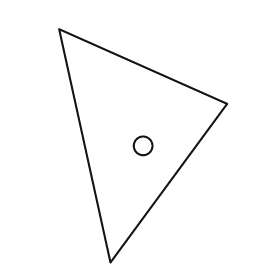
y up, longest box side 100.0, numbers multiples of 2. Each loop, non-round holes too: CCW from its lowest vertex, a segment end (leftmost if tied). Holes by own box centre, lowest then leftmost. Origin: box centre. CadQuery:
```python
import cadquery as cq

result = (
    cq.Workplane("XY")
    .moveTo(-14.0, -50.0)
    .lineTo(36.0, 18.0)
    .lineTo(-36.0, 50.0)
    .close()
    .moveTo(0.0, 0.0)
    .circle(4.0)
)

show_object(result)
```